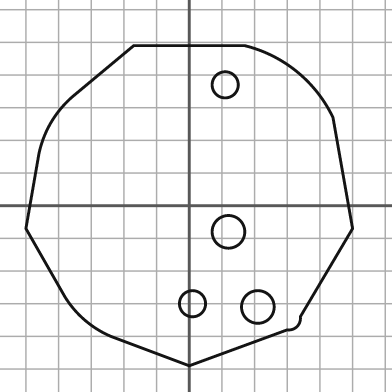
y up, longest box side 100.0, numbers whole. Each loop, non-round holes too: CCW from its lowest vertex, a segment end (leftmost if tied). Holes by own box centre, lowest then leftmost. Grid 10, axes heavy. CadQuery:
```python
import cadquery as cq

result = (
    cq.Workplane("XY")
    .moveTo(0.0, -49.0)
    .lineTo(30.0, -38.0)
    .threePointArc((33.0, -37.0), (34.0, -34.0))
    .lineTo(50.0, -7.0)
    .lineTo(44.0, 27.0)
    .threePointArc((33.0, 41.0), (17.0, 49.0))
    .lineTo(-17.0, 49.0)
    .lineTo(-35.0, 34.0)
    .threePointArc((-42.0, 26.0), (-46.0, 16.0))
    .lineTo(-50.0, -7.0)
    .lineTo(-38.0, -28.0)
    .threePointArc((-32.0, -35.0), (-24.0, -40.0))
    .close()
    .moveTo(21.0, -31.0)
    .circle(5.0)
    .moveTo(1.0, -30.0)
    .circle(4.0)
    .moveTo(12.0, -8.0)
    .circle(5.0)
    .moveTo(11.0, 37.0)
    .circle(4.0)
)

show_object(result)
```